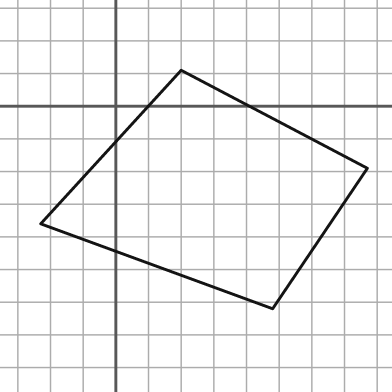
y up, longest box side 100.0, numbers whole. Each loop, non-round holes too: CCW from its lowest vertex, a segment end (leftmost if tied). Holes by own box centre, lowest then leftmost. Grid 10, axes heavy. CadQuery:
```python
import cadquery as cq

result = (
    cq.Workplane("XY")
    .moveTo(48.0, -62.0)
    .lineTo(77.0, -19.0)
    .lineTo(20.0, 11.0)
    .lineTo(-23.0, -36.0)
    .close()
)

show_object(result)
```